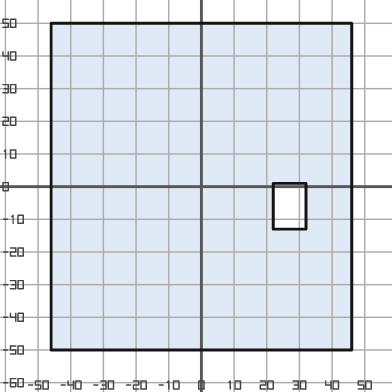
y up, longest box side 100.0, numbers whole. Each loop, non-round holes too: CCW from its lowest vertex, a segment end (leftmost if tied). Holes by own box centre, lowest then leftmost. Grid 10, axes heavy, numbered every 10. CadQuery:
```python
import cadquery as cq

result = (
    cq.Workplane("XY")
    .moveTo(-46.0, -50.0)
    .lineTo(46.0, -50.0)
    .lineTo(46.0, 50.0)
    .lineTo(-46.0, 50.0)
    .close()
    .moveTo(22.0, -13.0)
    .lineTo(32.0, -13.0)
    .lineTo(32.0, 1.0)
    .lineTo(22.0, 1.0)
    .close()
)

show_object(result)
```